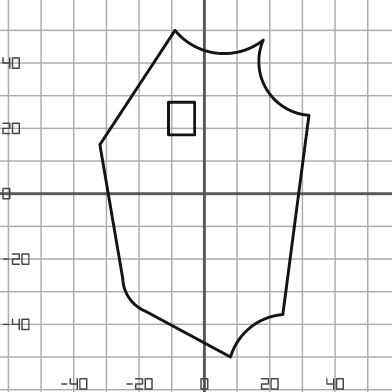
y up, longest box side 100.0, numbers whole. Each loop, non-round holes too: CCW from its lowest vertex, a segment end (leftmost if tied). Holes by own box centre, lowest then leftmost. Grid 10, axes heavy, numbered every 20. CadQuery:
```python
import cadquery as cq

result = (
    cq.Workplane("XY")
    .moveTo(8.0, -50.0)
    .threePointArc((14.0, -41.0), (24.0, -37.0))
    .lineTo(32.0, 24.0)
    .threePointArc((19.0, 32.0), (18.0, 47.0))
    .threePointArc((4.0, 43.0), (-9.0, 50.0))
    .lineTo(-32.0, 15.0)
    .lineTo(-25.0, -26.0)
    .threePointArc((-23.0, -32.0), (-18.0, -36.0))
    .close()
    .moveTo(-11.0, 18.0)
    .lineTo(-3.0, 18.0)
    .lineTo(-3.0, 28.0)
    .lineTo(-11.0, 28.0)
    .close()
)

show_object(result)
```